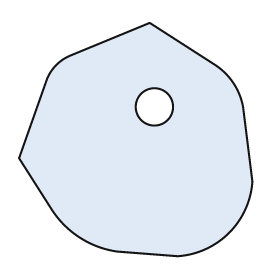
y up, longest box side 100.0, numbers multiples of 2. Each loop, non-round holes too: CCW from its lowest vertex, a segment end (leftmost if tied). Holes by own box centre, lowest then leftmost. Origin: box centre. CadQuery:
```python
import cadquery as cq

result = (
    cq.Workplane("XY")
    .moveTo(18.0, -50.0)
    .threePointArc((40.0, -40.0), (50.0, -18.0))
    .lineTo(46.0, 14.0)
    .threePointArc((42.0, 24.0), (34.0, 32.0))
    .lineTo(6.0, 50.0)
    .lineTo(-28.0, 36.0)
    .threePointArc((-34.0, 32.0), (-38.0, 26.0))
    .lineTo(-50.0, -8.0)
    .lineTo(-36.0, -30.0)
    .threePointArc((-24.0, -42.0), (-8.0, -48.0))
    .close()
    .moveTo(8.0, 14.0)
    .circle(8.0)
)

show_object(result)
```